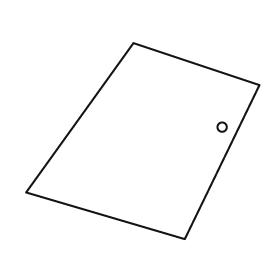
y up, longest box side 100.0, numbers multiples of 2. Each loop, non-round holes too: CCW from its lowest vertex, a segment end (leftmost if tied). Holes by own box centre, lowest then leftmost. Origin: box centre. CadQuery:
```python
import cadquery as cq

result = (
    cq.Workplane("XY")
    .moveTo(18.0, -42.0)
    .lineTo(50.0, 24.0)
    .lineTo(-4.0, 42.0)
    .lineTo(-50.0, -22.0)
    .close()
    .moveTo(34.0, 6.0)
    .circle(2.0)
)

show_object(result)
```